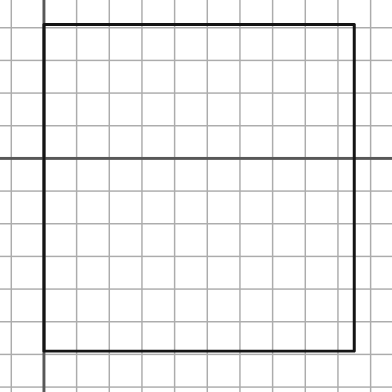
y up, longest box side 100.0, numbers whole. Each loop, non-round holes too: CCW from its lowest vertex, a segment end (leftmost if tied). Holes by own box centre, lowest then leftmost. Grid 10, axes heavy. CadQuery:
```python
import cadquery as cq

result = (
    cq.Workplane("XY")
    .moveTo(0.0, -59.0)
    .lineTo(95.0, -59.0)
    .lineTo(95.0, 41.0)
    .lineTo(0.0, 41.0)
    .close()
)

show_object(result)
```